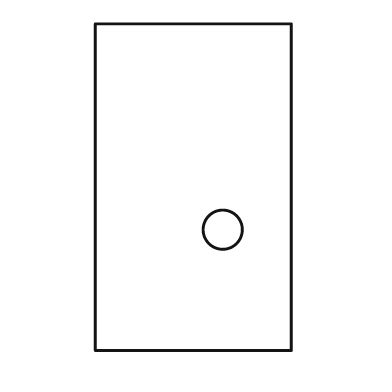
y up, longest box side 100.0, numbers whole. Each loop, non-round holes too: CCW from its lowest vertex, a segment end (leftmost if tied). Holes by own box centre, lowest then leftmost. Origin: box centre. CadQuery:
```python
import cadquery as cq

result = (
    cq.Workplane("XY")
    .moveTo(-30.0, -50.0)
    .lineTo(30.0, -50.0)
    .lineTo(30.0, 50.0)
    .lineTo(-30.0, 50.0)
    .close()
    .moveTo(9.0, -13.0)
    .circle(6.0)
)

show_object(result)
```